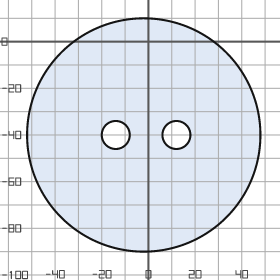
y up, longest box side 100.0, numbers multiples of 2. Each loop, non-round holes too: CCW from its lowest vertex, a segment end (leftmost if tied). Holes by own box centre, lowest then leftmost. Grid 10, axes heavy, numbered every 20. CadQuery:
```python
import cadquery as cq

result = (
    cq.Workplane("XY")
    .moveTo(-2.0, -40.0)
    .circle(50.0)
    .moveTo(-14.0, -40.0)
    .circle(6.0)
    .moveTo(12.0, -40.0)
    .circle(6.0)
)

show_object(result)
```